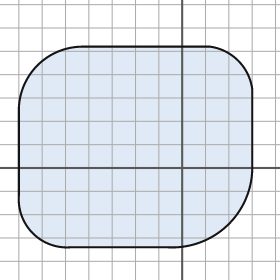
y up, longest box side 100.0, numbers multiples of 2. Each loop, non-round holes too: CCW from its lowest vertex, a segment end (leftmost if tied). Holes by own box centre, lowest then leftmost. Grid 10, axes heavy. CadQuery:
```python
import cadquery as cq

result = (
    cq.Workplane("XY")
    .moveTo(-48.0, -34.0)
    .lineTo(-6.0, -34.0)
    .threePointArc((20.0, -24.0), (30.0, 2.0))
    .lineTo(30.0, 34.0)
    .threePointArc((24.0, 46.0), (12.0, 52.0))
    .lineTo(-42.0, 52.0)
    .threePointArc((-62.0, 44.0), (-70.0, 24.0))
    .lineTo(-70.0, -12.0)
    .threePointArc((-64.0, -28.0), (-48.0, -34.0))
    .close()
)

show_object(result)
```